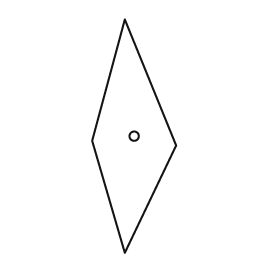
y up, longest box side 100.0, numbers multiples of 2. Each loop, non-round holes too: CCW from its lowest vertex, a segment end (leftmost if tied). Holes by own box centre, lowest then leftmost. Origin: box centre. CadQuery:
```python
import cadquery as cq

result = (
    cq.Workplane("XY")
    .moveTo(-4.0, -50.0)
    .lineTo(18.0, -4.0)
    .lineTo(-4.0, 50.0)
    .lineTo(-18.0, -2.0)
    .close()
    .moveTo(0.0, 0.0)
    .circle(2.0)
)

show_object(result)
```